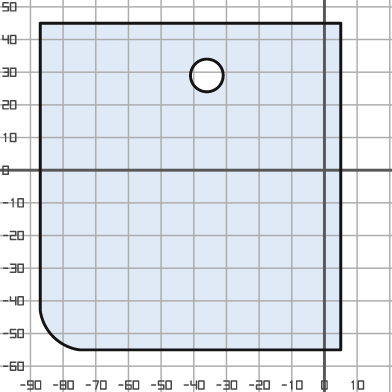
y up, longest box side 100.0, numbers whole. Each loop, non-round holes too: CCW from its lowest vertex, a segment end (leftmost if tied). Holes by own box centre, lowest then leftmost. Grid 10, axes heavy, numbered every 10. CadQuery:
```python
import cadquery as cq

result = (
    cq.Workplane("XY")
    .moveTo(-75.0, -55.0)
    .lineTo(5.0, -55.0)
    .lineTo(5.0, 45.0)
    .lineTo(-87.0, 45.0)
    .lineTo(-87.0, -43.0)
    .threePointArc((-83.0, -51.0), (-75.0, -55.0))
    .close()
    .moveTo(-36.0, 29.0)
    .circle(5.0)
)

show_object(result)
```